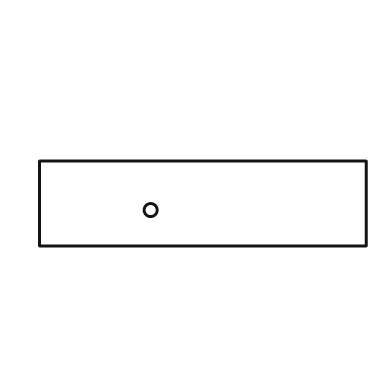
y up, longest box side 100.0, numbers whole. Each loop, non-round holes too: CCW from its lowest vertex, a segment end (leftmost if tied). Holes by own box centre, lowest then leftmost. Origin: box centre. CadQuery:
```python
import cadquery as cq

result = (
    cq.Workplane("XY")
    .moveTo(-50.0, -13.0)
    .lineTo(50.0, -13.0)
    .lineTo(50.0, 13.0)
    .lineTo(-50.0, 13.0)
    .close()
    .moveTo(-16.0, -2.0)
    .circle(2.0)
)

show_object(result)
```